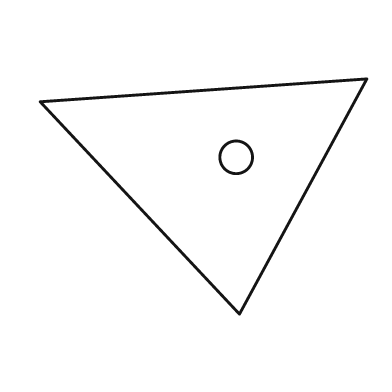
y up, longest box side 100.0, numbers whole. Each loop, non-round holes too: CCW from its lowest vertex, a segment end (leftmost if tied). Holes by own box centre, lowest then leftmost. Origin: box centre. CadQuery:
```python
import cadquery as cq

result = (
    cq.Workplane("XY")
    .moveTo(11.0, -36.0)
    .lineTo(50.0, 36.0)
    .lineTo(-50.0, 29.0)
    .close()
    .moveTo(10.0, 12.0)
    .circle(5.0)
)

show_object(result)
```